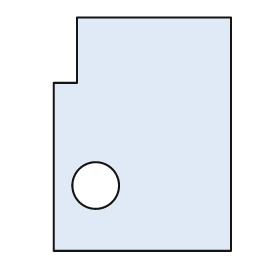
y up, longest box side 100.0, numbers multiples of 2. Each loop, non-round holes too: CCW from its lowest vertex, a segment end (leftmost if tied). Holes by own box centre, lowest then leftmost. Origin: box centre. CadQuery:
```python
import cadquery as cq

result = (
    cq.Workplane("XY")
    .moveTo(-38.0, -50.0)
    .lineTo(38.0, -50.0)
    .lineTo(38.0, 50.0)
    .lineTo(-28.0, 50.0)
    .lineTo(-28.0, 22.0)
    .lineTo(-38.0, 22.0)
    .close()
    .moveTo(-20.0, -22.0)
    .circle(10.0)
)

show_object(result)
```